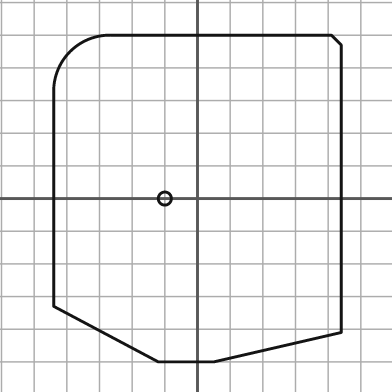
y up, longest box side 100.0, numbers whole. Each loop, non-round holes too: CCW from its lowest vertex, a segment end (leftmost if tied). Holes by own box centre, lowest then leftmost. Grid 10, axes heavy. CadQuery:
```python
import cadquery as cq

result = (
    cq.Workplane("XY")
    .moveTo(-12.0, -50.0)
    .lineTo(5.0, -50.0)
    .lineTo(44.0, -41.0)
    .lineTo(44.0, 47.0)
    .lineTo(41.0, 50.0)
    .lineTo(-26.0, 50.0)
    .threePointArc((-39.0, 45.0), (-44.0, 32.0))
    .lineTo(-44.0, -33.0)
    .close()
    .moveTo(-10.0, 0.0)
    .circle(2.0)
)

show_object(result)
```